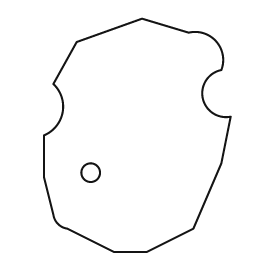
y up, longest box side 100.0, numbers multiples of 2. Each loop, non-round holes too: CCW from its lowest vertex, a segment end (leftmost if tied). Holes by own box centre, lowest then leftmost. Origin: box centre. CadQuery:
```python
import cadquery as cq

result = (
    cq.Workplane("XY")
    .moveTo(-10.0, -50.0)
    .lineTo(4.0, -50.0)
    .lineTo(24.0, -40.0)
    .lineTo(36.0, -12.0)
    .lineTo(40.0, 8.0)
    .threePointArc((28.0, 16.0), (36.0, 28.0))
    .threePointArc((34.0, 40.0), (22.0, 44.0))
    .lineTo(2.0, 50.0)
    .lineTo(-26.0, 40.0)
    .lineTo(-36.0, 22.0)
    .threePointArc((-32.0, 10.0), (-40.0, 0.0))
    .lineTo(-40.0, -18.0)
    .lineTo(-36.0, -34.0)
    .threePointArc((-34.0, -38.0), (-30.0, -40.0))
    .close()
    .moveTo(-20.0, -16.0)
    .circle(4.0)
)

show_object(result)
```